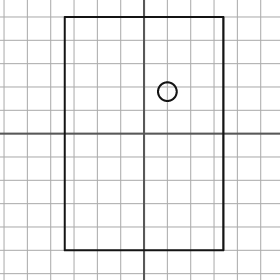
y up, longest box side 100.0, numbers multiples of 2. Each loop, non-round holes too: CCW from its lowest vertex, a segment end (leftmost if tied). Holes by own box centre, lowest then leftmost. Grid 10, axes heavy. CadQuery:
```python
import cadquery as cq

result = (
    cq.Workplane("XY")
    .moveTo(-34.0, -50.0)
    .lineTo(34.0, -50.0)
    .lineTo(34.0, 50.0)
    .lineTo(-34.0, 50.0)
    .close()
    .moveTo(10.0, 18.0)
    .circle(4.0)
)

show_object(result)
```